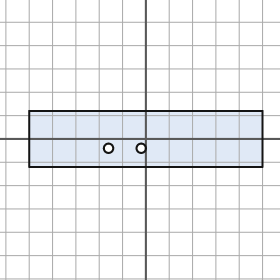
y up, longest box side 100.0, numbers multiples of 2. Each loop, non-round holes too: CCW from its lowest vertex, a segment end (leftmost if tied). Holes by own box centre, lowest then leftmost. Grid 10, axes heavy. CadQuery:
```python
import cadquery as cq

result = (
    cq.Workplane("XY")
    .moveTo(-50.0, -12.0)
    .lineTo(50.0, -12.0)
    .lineTo(50.0, 12.0)
    .lineTo(-50.0, 12.0)
    .close()
    .moveTo(-16.0, -4.0)
    .circle(2.0)
    .moveTo(-2.0, -4.0)
    .circle(2.0)
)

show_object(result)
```